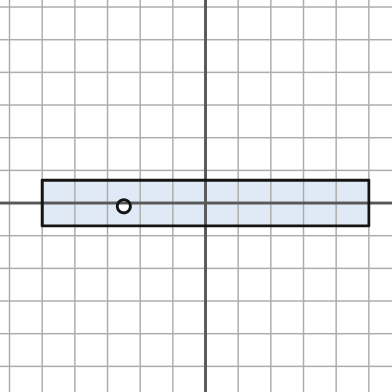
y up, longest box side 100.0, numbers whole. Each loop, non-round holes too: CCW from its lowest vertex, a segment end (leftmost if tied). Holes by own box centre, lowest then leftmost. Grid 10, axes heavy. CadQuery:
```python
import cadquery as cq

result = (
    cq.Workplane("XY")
    .moveTo(-50.0, -7.0)
    .lineTo(50.0, -7.0)
    .lineTo(50.0, 7.0)
    .lineTo(-50.0, 7.0)
    .close()
    .moveTo(-25.0, -1.0)
    .circle(2.0)
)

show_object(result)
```